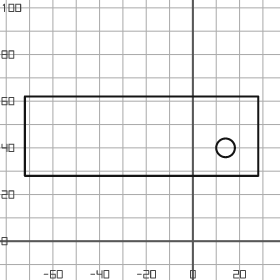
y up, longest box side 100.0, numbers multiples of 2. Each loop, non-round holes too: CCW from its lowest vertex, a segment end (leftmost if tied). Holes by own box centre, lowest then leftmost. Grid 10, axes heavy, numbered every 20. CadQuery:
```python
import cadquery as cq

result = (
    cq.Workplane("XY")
    .moveTo(-72.0, 28.0)
    .lineTo(28.0, 28.0)
    .lineTo(28.0, 62.0)
    .lineTo(-72.0, 62.0)
    .close()
    .moveTo(14.0, 40.0)
    .circle(4.0)
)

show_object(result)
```